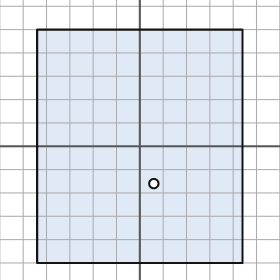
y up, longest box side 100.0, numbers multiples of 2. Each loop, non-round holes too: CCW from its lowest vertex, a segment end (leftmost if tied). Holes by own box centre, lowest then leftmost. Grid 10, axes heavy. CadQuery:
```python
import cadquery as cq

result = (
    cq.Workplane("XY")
    .moveTo(-44.0, -50.0)
    .lineTo(44.0, -50.0)
    .lineTo(44.0, 50.0)
    .lineTo(-44.0, 50.0)
    .close()
    .moveTo(6.0, -16.0)
    .circle(2.0)
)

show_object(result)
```